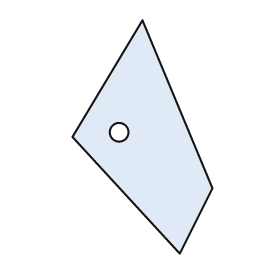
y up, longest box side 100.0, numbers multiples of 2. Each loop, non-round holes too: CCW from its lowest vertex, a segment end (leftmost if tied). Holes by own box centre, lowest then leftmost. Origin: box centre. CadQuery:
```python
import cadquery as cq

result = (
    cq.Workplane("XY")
    .moveTo(16.0, -50.0)
    .lineTo(30.0, -22.0)
    .lineTo(0.0, 50.0)
    .lineTo(-30.0, 0.0)
    .close()
    .moveTo(-10.0, 2.0)
    .circle(4.0)
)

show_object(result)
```